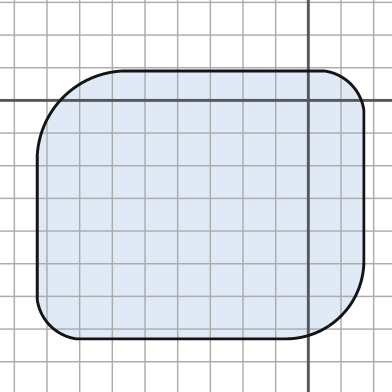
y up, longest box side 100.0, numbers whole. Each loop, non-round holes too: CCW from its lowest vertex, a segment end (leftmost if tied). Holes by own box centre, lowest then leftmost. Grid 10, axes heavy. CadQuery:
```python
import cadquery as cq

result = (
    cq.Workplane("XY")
    .moveTo(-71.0, -73.0)
    .lineTo(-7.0, -73.0)
    .threePointArc((10.0, -66.0), (17.0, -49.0))
    .lineTo(17.0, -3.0)
    .threePointArc((13.0, 5.0), (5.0, 9.0))
    .lineTo(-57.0, 9.0)
    .threePointArc((-75.0, 1.0), (-83.0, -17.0))
    .lineTo(-83.0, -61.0)
    .threePointArc((-79.0, -69.0), (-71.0, -73.0))
    .close()
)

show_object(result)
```